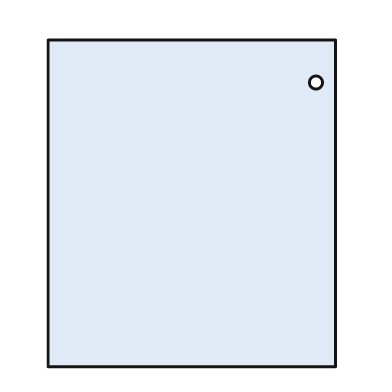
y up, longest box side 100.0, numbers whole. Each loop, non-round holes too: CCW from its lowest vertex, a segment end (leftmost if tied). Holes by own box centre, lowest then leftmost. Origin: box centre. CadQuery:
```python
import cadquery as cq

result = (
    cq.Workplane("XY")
    .moveTo(-44.0, -50.0)
    .lineTo(44.0, -50.0)
    .lineTo(44.0, 50.0)
    .lineTo(-44.0, 50.0)
    .close()
    .moveTo(38.0, 37.0)
    .circle(2.0)
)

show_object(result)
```